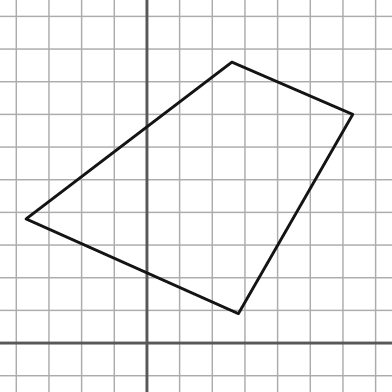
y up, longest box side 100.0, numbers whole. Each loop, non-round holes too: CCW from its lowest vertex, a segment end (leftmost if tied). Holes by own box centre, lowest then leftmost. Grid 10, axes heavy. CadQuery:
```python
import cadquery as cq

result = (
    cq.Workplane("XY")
    .moveTo(28.0, 9.0)
    .lineTo(63.0, 70.0)
    .lineTo(26.0, 86.0)
    .lineTo(-37.0, 38.0)
    .close()
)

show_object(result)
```